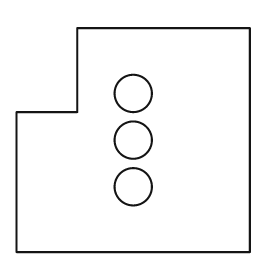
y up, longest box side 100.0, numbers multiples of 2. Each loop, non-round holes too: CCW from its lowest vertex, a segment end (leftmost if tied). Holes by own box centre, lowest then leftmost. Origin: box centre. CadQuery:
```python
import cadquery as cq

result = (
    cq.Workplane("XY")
    .moveTo(-50.0, -48.0)
    .lineTo(50.0, -48.0)
    .lineTo(50.0, 48.0)
    .lineTo(-24.0, 48.0)
    .lineTo(-24.0, 12.0)
    .lineTo(-50.0, 12.0)
    .close()
    .moveTo(0.0, -20.0)
    .circle(8.0)
    .moveTo(0.0, 0.0)
    .circle(8.0)
    .moveTo(0.0, 20.0)
    .circle(8.0)
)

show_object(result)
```